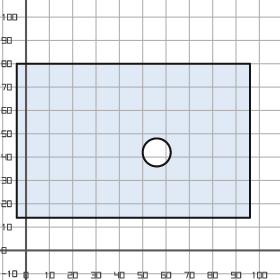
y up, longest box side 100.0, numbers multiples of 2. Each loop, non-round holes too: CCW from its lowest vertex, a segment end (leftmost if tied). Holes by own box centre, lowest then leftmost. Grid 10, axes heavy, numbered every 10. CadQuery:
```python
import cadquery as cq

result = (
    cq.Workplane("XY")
    .moveTo(-4.0, 14.0)
    .lineTo(96.0, 14.0)
    .lineTo(96.0, 80.0)
    .lineTo(-4.0, 80.0)
    .close()
    .moveTo(56.0, 42.0)
    .circle(6.0)
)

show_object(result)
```